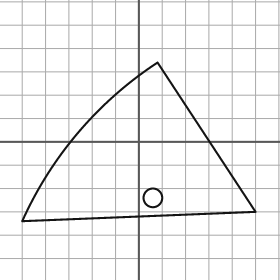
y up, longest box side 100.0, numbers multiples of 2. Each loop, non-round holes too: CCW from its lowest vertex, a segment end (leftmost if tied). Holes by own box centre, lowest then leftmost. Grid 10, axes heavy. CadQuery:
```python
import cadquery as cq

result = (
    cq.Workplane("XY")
    .moveTo(-50.0, -34.0)
    .lineTo(50.0, -30.0)
    .lineTo(8.0, 34.0)
    .threePointArc((-26.0, 4.0), (-50.0, -34.0))
    .close()
    .moveTo(6.0, -24.0)
    .circle(4.0)
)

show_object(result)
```